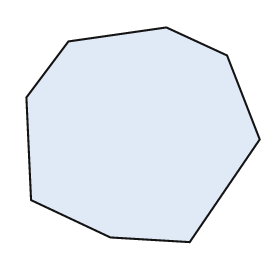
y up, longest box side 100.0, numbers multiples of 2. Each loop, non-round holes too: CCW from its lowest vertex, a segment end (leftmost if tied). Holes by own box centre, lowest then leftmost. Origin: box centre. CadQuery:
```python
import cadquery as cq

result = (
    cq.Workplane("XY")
    .moveTo(20.0, -46.0)
    .lineTo(50.0, -2.0)
    .lineTo(36.0, 34.0)
    .lineTo(10.0, 46.0)
    .lineTo(-32.0, 40.0)
    .lineTo(-50.0, 16.0)
    .lineTo(-48.0, -28.0)
    .lineTo(-14.0, -44.0)
    .close()
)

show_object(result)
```